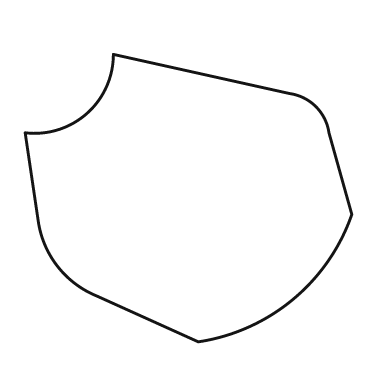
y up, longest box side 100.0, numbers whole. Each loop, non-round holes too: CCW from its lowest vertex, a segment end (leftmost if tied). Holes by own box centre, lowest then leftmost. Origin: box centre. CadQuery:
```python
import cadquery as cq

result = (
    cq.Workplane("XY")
    .moveTo(3.0, -44.0)
    .threePointArc((32.0, -31.0), (50.0, -5.0))
    .lineTo(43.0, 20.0)
    .threePointArc((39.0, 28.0), (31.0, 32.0))
    .lineTo(-23.0, 44.0)
    .threePointArc((-31.0, 26.0), (-50.0, 20.0))
    .lineTo(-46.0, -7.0)
    .threePointArc((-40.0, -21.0), (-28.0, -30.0))
    .close()
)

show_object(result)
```